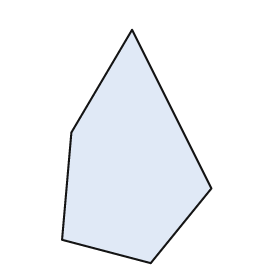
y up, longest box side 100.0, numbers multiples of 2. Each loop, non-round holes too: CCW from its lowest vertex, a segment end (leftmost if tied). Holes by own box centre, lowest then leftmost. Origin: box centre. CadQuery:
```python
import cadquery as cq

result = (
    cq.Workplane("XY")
    .moveTo(6.0, -50.0)
    .lineTo(32.0, -18.0)
    .lineTo(-2.0, 50.0)
    .lineTo(-28.0, 6.0)
    .lineTo(-32.0, -40.0)
    .close()
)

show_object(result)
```